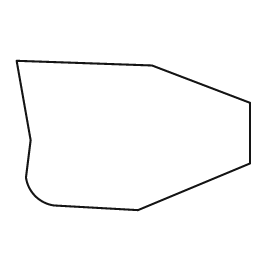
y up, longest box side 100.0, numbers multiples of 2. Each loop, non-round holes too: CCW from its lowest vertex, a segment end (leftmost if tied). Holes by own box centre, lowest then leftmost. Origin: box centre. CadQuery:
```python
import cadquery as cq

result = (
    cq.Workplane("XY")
    .moveTo(2.0, -32.0)
    .lineTo(50.0, -12.0)
    .lineTo(50.0, 14.0)
    .lineTo(8.0, 30.0)
    .lineTo(-50.0, 32.0)
    .lineTo(-44.0, -2.0)
    .lineTo(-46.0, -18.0)
    .threePointArc((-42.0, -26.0), (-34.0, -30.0))
    .close()
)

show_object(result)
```